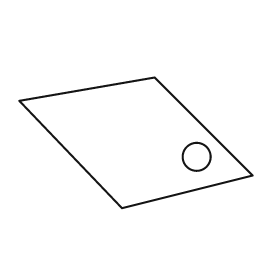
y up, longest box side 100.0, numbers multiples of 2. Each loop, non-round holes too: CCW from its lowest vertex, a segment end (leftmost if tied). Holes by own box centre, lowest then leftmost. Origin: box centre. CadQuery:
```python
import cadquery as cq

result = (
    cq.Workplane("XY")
    .moveTo(-6.0, -28.0)
    .lineTo(50.0, -14.0)
    .lineTo(8.0, 28.0)
    .lineTo(-50.0, 18.0)
    .close()
    .moveTo(26.0, -6.0)
    .circle(6.0)
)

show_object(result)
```